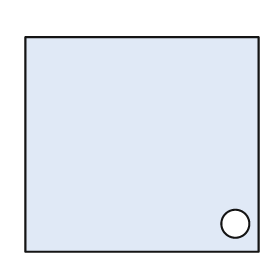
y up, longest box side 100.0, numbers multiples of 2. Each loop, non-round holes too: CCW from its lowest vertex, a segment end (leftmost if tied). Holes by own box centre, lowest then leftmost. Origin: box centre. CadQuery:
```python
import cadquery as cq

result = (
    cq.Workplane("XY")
    .moveTo(-50.0, -46.0)
    .lineTo(50.0, -46.0)
    .lineTo(50.0, 46.0)
    .lineTo(-50.0, 46.0)
    .close()
    .moveTo(40.0, -34.0)
    .circle(6.0)
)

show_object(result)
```